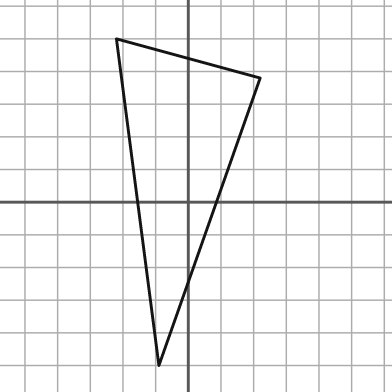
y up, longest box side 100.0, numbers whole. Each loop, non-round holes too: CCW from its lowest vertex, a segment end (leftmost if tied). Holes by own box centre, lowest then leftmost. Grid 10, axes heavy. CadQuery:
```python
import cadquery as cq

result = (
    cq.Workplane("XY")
    .moveTo(-9.0, -50.0)
    .lineTo(22.0, 38.0)
    .lineTo(-22.0, 50.0)
    .close()
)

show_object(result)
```